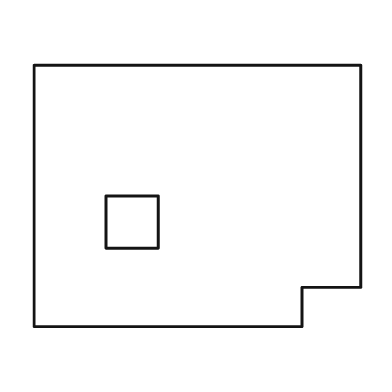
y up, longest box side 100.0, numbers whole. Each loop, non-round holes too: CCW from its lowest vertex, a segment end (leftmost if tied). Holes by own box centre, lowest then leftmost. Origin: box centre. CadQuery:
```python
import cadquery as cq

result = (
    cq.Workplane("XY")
    .moveTo(-50.0, -40.0)
    .lineTo(32.0, -40.0)
    .lineTo(32.0, -28.0)
    .lineTo(50.0, -28.0)
    .lineTo(50.0, 40.0)
    .lineTo(-50.0, 40.0)
    .close()
    .moveTo(-28.0, -16.0)
    .lineTo(-12.0, -16.0)
    .lineTo(-12.0, 0.0)
    .lineTo(-28.0, 0.0)
    .close()
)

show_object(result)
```